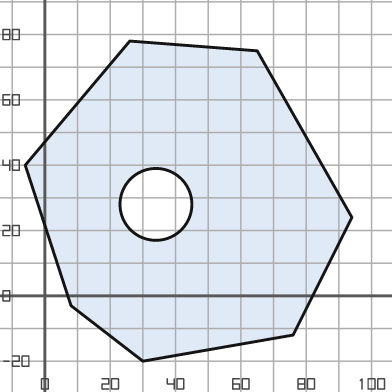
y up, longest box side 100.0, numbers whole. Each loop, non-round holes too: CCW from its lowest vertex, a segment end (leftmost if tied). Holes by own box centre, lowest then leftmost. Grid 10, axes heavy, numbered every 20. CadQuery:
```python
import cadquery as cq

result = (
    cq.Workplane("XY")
    .moveTo(30.0, -20.0)
    .lineTo(76.0, -12.0)
    .lineTo(94.0, 24.0)
    .lineTo(65.0, 75.0)
    .lineTo(26.0, 78.0)
    .lineTo(-6.0, 40.0)
    .lineTo(8.0, -3.0)
    .close()
    .moveTo(34.0, 28.0)
    .circle(11.0)
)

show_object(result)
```